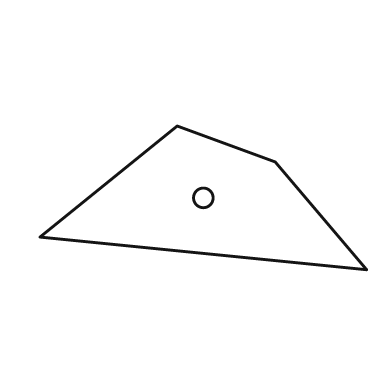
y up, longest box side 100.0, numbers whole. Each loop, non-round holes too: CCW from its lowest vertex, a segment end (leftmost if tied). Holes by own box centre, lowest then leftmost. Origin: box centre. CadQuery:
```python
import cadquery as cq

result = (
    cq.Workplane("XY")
    .moveTo(50.0, -22.0)
    .lineTo(22.0, 11.0)
    .lineTo(-8.0, 22.0)
    .lineTo(-50.0, -12.0)
    .close()
    .moveTo(0.0, 0.0)
    .circle(3.0)
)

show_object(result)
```